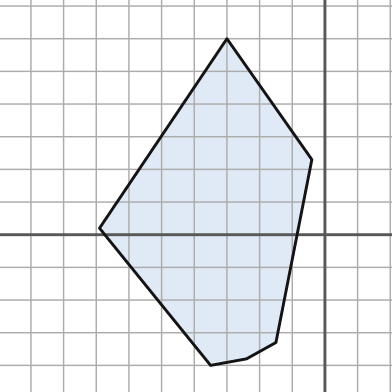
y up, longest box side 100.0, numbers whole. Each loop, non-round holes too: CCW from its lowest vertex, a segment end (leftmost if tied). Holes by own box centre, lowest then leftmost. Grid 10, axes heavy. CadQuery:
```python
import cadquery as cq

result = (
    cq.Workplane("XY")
    .moveTo(-35.0, -40.0)
    .lineTo(-24.0, -38.0)
    .lineTo(-15.0, -33.0)
    .lineTo(-4.0, 23.0)
    .lineTo(-30.0, 60.0)
    .lineTo(-69.0, 2.0)
    .close()
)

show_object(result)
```